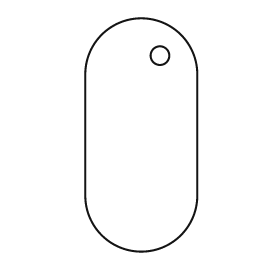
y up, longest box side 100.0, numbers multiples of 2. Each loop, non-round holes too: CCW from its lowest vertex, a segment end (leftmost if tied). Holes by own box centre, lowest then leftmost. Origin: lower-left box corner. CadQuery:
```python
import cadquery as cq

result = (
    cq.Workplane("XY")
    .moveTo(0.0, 24.0)
    .threePointArc((24.0, 0.0), (48.0, 24.0))
    .lineTo(48.0, 76.0)
    .threePointArc((24.0, 100.0), (0.0, 76.0))
    .close()
    .moveTo(32.0, 84.0)
    .circle(4.0)
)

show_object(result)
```